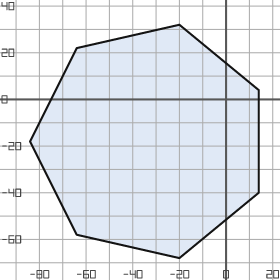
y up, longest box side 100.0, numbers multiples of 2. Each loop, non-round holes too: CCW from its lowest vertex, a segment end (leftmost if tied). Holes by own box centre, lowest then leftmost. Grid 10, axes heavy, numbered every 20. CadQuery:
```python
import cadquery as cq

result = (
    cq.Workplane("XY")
    .moveTo(-20.0, -68.0)
    .lineTo(14.0, -40.0)
    .lineTo(14.0, 4.0)
    .lineTo(-20.0, 32.0)
    .lineTo(-64.0, 22.0)
    .lineTo(-84.0, -18.0)
    .lineTo(-64.0, -58.0)
    .close()
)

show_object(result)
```